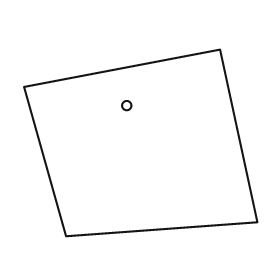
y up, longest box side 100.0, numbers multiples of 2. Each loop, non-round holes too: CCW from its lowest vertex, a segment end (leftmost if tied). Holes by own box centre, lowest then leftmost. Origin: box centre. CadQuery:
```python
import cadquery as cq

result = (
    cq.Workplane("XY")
    .moveTo(-32.0, -40.0)
    .lineTo(50.0, -34.0)
    .lineTo(34.0, 40.0)
    .lineTo(-50.0, 24.0)
    .close()
    .moveTo(-6.0, 16.0)
    .circle(2.0)
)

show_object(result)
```